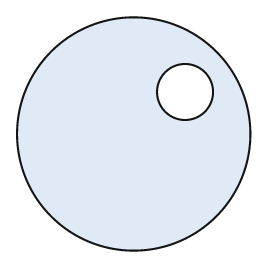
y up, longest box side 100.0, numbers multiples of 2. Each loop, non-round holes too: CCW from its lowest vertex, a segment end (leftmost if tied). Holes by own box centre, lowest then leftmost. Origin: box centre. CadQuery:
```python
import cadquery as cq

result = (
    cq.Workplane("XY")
    .moveTo(0.0, 0.0)
    .circle(50.0)
    .moveTo(22.0, 18.0)
    .circle(12.0)
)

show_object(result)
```